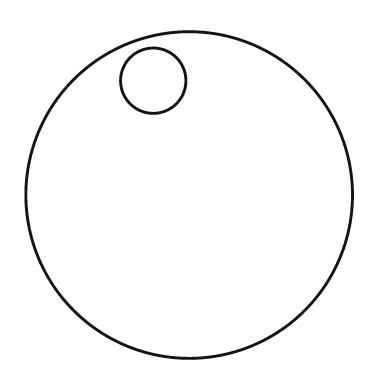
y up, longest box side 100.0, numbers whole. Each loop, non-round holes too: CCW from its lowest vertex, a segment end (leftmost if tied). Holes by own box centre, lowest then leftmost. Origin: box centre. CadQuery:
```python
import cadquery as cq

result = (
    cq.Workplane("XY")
    .moveTo(0.0, 0.0)
    .circle(50.0)
    .moveTo(-11.0, 35.0)
    .circle(10.0)
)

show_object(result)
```